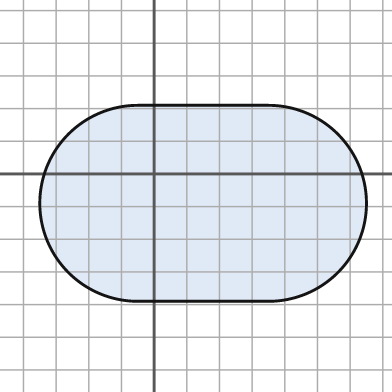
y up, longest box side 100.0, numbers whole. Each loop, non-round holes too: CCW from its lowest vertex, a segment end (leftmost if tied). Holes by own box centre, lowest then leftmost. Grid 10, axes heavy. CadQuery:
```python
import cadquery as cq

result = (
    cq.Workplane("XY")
    .moveTo(-5.0, -39.0)
    .lineTo(35.0, -39.0)
    .threePointArc((65.0, -9.0), (35.0, 21.0))
    .lineTo(-5.0, 21.0)
    .threePointArc((-35.0, -9.0), (-5.0, -39.0))
    .close()
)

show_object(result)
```